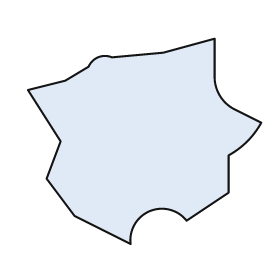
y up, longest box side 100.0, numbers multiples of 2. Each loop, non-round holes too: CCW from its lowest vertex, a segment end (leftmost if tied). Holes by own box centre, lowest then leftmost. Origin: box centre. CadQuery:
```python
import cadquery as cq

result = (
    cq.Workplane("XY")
    .moveTo(-6.0, -44.0)
    .threePointArc((2.0, -30.0), (18.0, -34.0))
    .lineTo(36.0, -22.0)
    .lineTo(36.0, -6.0)
    .threePointArc((44.0, 0.0), (50.0, 8.0))
    .lineTo(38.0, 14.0)
    .threePointArc((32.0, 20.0), (30.0, 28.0))
    .lineTo(30.0, 44.0)
    .lineTo(8.0, 38.0)
    .lineTo(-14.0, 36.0)
    .threePointArc((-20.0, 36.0), (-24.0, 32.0))
    .lineTo(-34.0, 26.0)
    .lineTo(-50.0, 22.0)
    .lineTo(-36.0, 0.0)
    .lineTo(-42.0, -16.0)
    .lineTo(-30.0, -32.0)
    .close()
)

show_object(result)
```